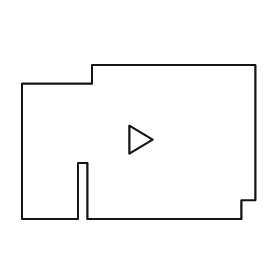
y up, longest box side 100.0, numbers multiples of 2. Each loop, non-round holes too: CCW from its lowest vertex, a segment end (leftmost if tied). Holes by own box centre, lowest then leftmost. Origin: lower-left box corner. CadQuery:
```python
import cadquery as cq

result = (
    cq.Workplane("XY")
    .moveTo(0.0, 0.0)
    .lineTo(24.0, 0.0)
    .lineTo(24.0, 24.0)
    .lineTo(28.0, 24.0)
    .lineTo(28.0, 0.0)
    .lineTo(94.0, 0.0)
    .lineTo(94.0, 8.0)
    .lineTo(100.0, 8.0)
    .lineTo(100.0, 66.0)
    .lineTo(30.0, 66.0)
    .lineTo(30.0, 58.0)
    .lineTo(0.0, 58.0)
    .close()
    .moveTo(46.0, 28.0)
    .lineTo(56.0, 34.0)
    .lineTo(46.0, 40.0)
    .close()
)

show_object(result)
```